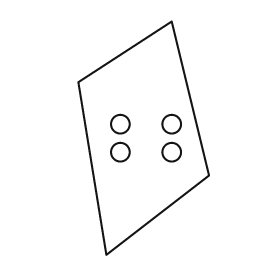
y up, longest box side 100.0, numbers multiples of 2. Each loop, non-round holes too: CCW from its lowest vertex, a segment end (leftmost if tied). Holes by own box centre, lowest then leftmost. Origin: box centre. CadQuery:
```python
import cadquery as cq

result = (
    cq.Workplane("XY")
    .moveTo(-16.0, -50.0)
    .lineTo(28.0, -16.0)
    .lineTo(12.0, 50.0)
    .lineTo(-28.0, 24.0)
    .close()
    .moveTo(-10.0, -6.0)
    .circle(4.0)
    .moveTo(12.0, -6.0)
    .circle(4.0)
    .moveTo(-10.0, 6.0)
    .circle(4.0)
    .moveTo(12.0, 6.0)
    .circle(4.0)
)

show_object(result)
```